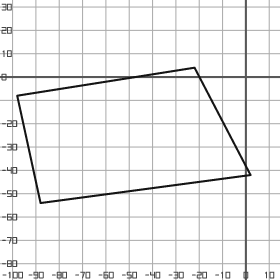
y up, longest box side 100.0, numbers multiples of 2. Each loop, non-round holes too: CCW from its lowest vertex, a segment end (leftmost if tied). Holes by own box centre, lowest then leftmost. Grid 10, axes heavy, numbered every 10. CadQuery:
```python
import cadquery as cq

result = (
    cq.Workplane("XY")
    .moveTo(-88.0, -54.0)
    .lineTo(2.0, -42.0)
    .lineTo(-22.0, 4.0)
    .lineTo(-98.0, -8.0)
    .close()
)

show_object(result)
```